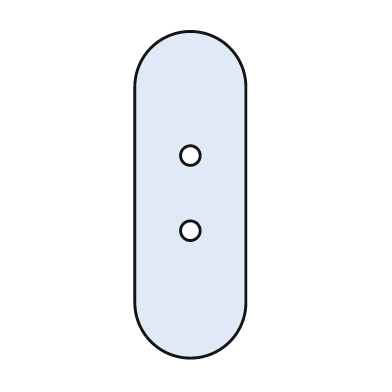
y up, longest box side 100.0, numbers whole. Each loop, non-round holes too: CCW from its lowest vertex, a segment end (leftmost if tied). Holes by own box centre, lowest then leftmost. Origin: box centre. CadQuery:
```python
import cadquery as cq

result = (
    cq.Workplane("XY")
    .moveTo(-17.0, -33.0)
    .threePointArc((0.0, -50.0), (17.0, -33.0))
    .lineTo(17.0, 33.0)
    .threePointArc((0.0, 50.0), (-17.0, 33.0))
    .close()
    .moveTo(0.0, -11.0)
    .circle(3.0)
    .moveTo(0.0, 12.0)
    .circle(3.0)
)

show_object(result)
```